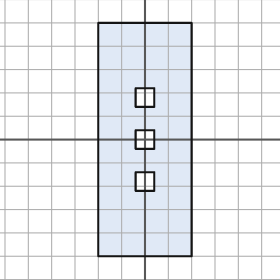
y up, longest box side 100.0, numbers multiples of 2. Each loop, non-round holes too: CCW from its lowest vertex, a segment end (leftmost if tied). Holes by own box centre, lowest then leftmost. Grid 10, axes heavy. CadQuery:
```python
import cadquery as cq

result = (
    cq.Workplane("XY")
    .moveTo(-20.0, -50.0)
    .lineTo(20.0, -50.0)
    .lineTo(20.0, 50.0)
    .lineTo(-20.0, 50.0)
    .close()
    .moveTo(-4.0, -22.0)
    .lineTo(4.0, -22.0)
    .lineTo(4.0, -14.0)
    .lineTo(-4.0, -14.0)
    .close()
    .moveTo(-4.0, -4.0)
    .lineTo(4.0, -4.0)
    .lineTo(4.0, 4.0)
    .lineTo(-4.0, 4.0)
    .close()
    .moveTo(-4.0, 14.0)
    .lineTo(4.0, 14.0)
    .lineTo(4.0, 22.0)
    .lineTo(-4.0, 22.0)
    .close()
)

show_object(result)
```